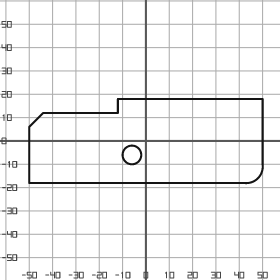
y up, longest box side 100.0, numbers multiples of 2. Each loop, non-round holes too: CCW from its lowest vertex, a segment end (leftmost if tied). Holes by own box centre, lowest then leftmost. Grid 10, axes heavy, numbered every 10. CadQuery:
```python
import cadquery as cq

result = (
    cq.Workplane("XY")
    .moveTo(-50.0, -18.0)
    .lineTo(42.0, -18.0)
    .threePointArc((48.0, -16.0), (50.0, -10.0))
    .lineTo(50.0, 18.0)
    .lineTo(-12.0, 18.0)
    .lineTo(-12.0, 12.0)
    .lineTo(-44.0, 12.0)
    .lineTo(-50.0, 6.0)
    .close()
    .moveTo(-6.0, -6.0)
    .circle(4.0)
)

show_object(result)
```